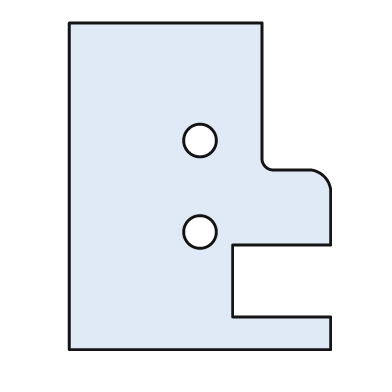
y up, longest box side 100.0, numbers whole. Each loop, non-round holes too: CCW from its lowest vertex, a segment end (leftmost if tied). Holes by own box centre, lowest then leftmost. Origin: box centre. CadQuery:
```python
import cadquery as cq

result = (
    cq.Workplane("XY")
    .moveTo(-40.0, -50.0)
    .lineTo(40.0, -50.0)
    .lineTo(40.0, -40.0)
    .lineTo(10.0, -40.0)
    .lineTo(10.0, -18.0)
    .lineTo(40.0, -18.0)
    .lineTo(40.0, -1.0)
    .threePointArc((38.0, 3.0), (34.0, 5.0))
    .lineTo(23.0, 5.0)
    .threePointArc((20.0, 6.0), (19.0, 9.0))
    .lineTo(19.0, 50.0)
    .lineTo(-40.0, 50.0)
    .close()
    .moveTo(0.0, -14.0)
    .circle(5.0)
    .moveTo(0.0, 14.0)
    .circle(5.0)
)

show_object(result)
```